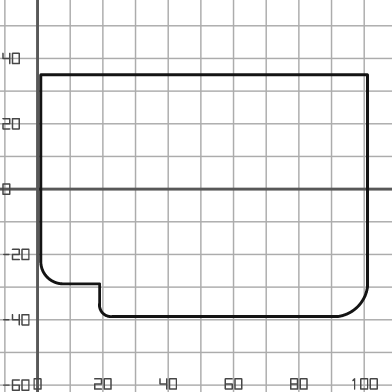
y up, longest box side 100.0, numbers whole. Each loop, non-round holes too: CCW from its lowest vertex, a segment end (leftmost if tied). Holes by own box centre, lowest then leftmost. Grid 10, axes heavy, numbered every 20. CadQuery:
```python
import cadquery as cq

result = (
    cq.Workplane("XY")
    .moveTo(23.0, -39.0)
    .lineTo(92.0, -39.0)
    .threePointArc((98.0, -36.0), (101.0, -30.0))
    .lineTo(101.0, 35.0)
    .lineTo(1.0, 35.0)
    .lineTo(1.0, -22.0)
    .threePointArc((3.0, -27.0), (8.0, -29.0))
    .lineTo(19.0, -29.0)
    .lineTo(19.0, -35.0)
    .threePointArc((20.0, -38.0), (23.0, -39.0))
    .close()
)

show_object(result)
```